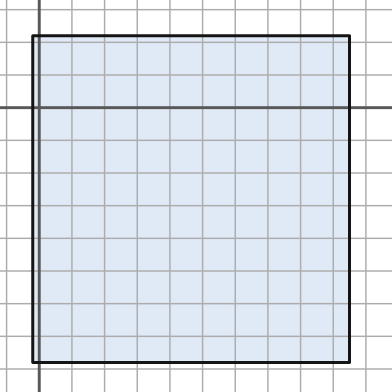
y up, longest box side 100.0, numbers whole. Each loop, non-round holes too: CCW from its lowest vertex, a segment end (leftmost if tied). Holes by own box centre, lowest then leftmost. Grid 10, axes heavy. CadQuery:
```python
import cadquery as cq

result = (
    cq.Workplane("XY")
    .moveTo(-2.0, -78.0)
    .lineTo(95.0, -78.0)
    .lineTo(95.0, 22.0)
    .lineTo(-2.0, 22.0)
    .close()
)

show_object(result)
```